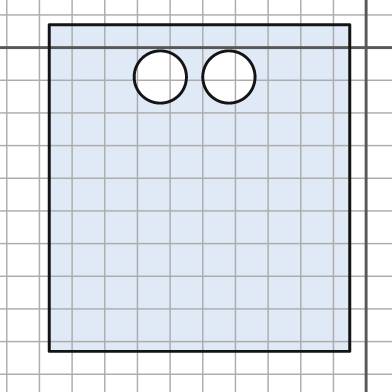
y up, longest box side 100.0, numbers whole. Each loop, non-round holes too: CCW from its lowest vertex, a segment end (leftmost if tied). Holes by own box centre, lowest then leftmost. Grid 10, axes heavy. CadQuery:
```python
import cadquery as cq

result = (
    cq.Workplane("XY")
    .moveTo(-97.0, -93.0)
    .lineTo(-5.0, -93.0)
    .lineTo(-5.0, 7.0)
    .lineTo(-97.0, 7.0)
    .close()
    .moveTo(-63.0, -9.0)
    .circle(8.0)
    .moveTo(-42.0, -9.0)
    .circle(8.0)
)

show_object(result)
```